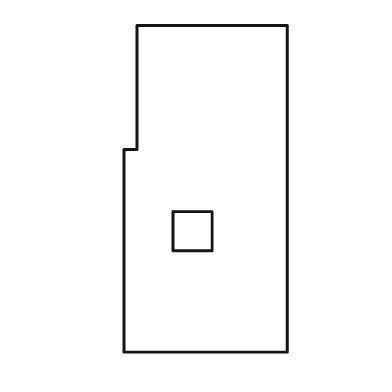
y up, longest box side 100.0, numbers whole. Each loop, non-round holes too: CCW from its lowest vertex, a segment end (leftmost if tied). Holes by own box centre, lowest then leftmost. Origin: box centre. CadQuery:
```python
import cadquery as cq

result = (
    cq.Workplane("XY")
    .moveTo(-25.0, -50.0)
    .lineTo(25.0, -50.0)
    .lineTo(25.0, 50.0)
    .lineTo(-21.0, 50.0)
    .lineTo(-21.0, 12.0)
    .lineTo(-25.0, 12.0)
    .close()
    .moveTo(-10.0, -19.0)
    .lineTo(2.0, -19.0)
    .lineTo(2.0, -7.0)
    .lineTo(-10.0, -7.0)
    .close()
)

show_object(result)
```